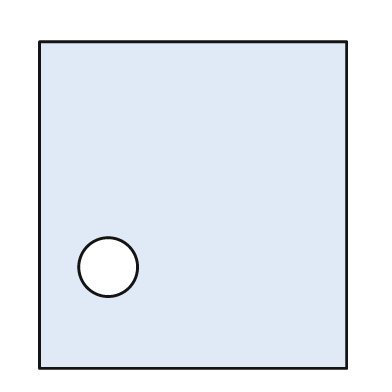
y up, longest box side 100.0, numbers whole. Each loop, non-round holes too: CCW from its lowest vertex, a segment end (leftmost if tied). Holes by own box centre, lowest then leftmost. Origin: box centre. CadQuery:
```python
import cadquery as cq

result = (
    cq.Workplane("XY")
    .moveTo(-47.0, -50.0)
    .lineTo(47.0, -50.0)
    .lineTo(47.0, 50.0)
    .lineTo(-47.0, 50.0)
    .close()
    .moveTo(-26.0, -19.0)
    .circle(9.0)
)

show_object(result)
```